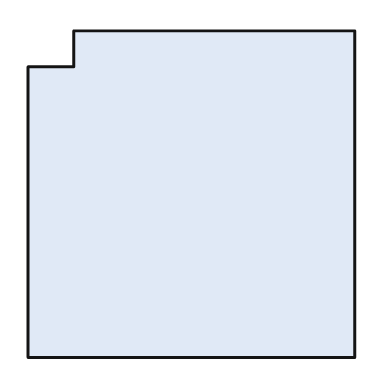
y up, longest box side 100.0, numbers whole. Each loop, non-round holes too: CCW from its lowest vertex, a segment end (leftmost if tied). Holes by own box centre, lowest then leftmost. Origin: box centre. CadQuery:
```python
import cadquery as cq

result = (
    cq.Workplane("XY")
    .moveTo(-50.0, -50.0)
    .lineTo(50.0, -50.0)
    .lineTo(50.0, 50.0)
    .lineTo(-36.0, 50.0)
    .lineTo(-36.0, 39.0)
    .lineTo(-50.0, 39.0)
    .close()
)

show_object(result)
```